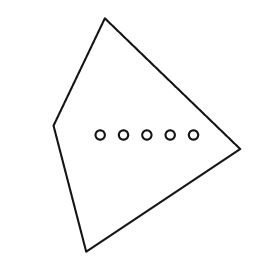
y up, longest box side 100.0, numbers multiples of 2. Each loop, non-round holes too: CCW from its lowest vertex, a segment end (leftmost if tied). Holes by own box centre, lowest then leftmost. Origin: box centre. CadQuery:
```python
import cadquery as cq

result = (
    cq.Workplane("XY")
    .moveTo(-26.0, -50.0)
    .lineTo(40.0, -6.0)
    .lineTo(-18.0, 50.0)
    .lineTo(-40.0, 4.0)
    .close()
    .moveTo(-20.0, 0.0)
    .circle(2.0)
    .moveTo(-10.0, 0.0)
    .circle(2.0)
    .moveTo(0.0, 0.0)
    .circle(2.0)
    .moveTo(10.0, 0.0)
    .circle(2.0)
    .moveTo(20.0, 0.0)
    .circle(2.0)
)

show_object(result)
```